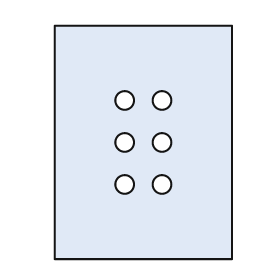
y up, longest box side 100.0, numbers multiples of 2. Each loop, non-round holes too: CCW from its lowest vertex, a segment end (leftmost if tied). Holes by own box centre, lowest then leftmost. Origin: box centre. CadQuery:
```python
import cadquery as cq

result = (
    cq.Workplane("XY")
    .moveTo(-38.0, -50.0)
    .lineTo(38.0, -50.0)
    .lineTo(38.0, 50.0)
    .lineTo(-38.0, 50.0)
    .close()
    .moveTo(-8.0, -18.0)
    .circle(4.0)
    .moveTo(8.0, -18.0)
    .circle(4.0)
    .moveTo(-8.0, 0.0)
    .circle(4.0)
    .moveTo(8.0, 0.0)
    .circle(4.0)
    .moveTo(-8.0, 18.0)
    .circle(4.0)
    .moveTo(8.0, 18.0)
    .circle(4.0)
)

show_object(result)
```